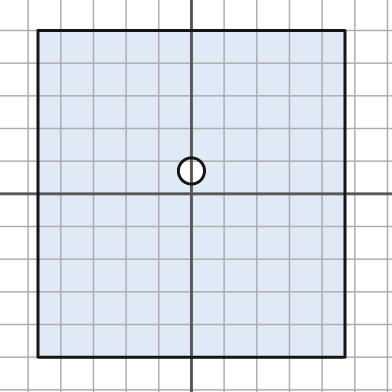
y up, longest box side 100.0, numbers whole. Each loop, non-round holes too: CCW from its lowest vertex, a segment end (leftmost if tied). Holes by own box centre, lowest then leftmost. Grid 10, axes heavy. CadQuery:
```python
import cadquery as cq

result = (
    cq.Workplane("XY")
    .moveTo(-47.0, -50.0)
    .lineTo(47.0, -50.0)
    .lineTo(47.0, 50.0)
    .lineTo(-47.0, 50.0)
    .close()
    .moveTo(0.0, 7.0)
    .circle(4.0)
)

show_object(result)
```